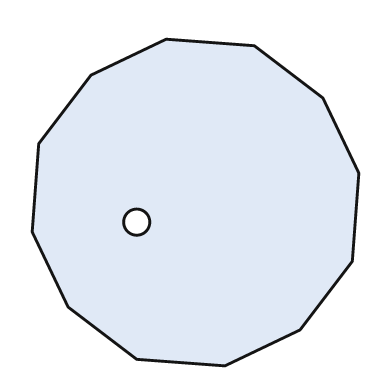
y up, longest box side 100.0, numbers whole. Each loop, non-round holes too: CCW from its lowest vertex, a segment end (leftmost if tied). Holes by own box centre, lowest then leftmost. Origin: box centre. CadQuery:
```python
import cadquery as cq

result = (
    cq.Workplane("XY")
    .moveTo(9.0, -50.0)
    .lineTo(32.0, -39.0)
    .lineTo(48.0, -18.0)
    .lineTo(50.0, 9.0)
    .lineTo(39.0, 32.0)
    .lineTo(18.0, 48.0)
    .lineTo(-9.0, 50.0)
    .lineTo(-32.0, 39.0)
    .lineTo(-48.0, 18.0)
    .lineTo(-50.0, -9.0)
    .lineTo(-39.0, -32.0)
    .lineTo(-18.0, -48.0)
    .close()
    .moveTo(-18.0, -6.0)
    .circle(4.0)
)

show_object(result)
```